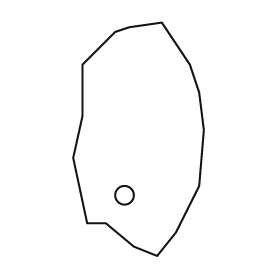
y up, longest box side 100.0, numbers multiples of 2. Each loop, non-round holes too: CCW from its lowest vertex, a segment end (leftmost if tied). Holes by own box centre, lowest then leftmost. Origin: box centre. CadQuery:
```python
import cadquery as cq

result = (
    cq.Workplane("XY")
    .moveTo(8.0, -50.0)
    .lineTo(16.0, -40.0)
    .lineTo(26.0, -20.0)
    .lineTo(28.0, 4.0)
    .lineTo(26.0, 20.0)
    .lineTo(22.0, 32.0)
    .lineTo(10.0, 50.0)
    .lineTo(-4.0, 48.0)
    .lineTo(-10.0, 46.0)
    .lineTo(-24.0, 32.0)
    .lineTo(-24.0, 10.0)
    .lineTo(-28.0, -8.0)
    .lineTo(-22.0, -36.0)
    .lineTo(-14.0, -36.0)
    .lineTo(-2.0, -46.0)
    .close()
    .moveTo(-6.0, -24.0)
    .circle(4.0)
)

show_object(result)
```